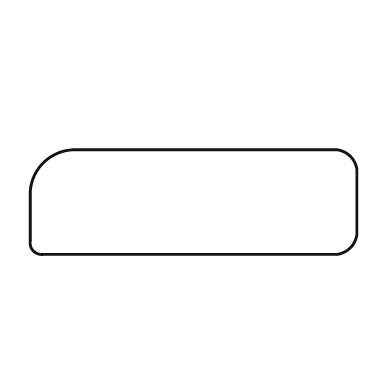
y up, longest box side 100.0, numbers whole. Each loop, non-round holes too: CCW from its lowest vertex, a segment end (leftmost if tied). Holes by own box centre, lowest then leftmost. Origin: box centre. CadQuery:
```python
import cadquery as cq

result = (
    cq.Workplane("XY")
    .moveTo(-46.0, -16.0)
    .lineTo(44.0, -16.0)
    .threePointArc((48.0, -14.0), (50.0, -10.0))
    .lineTo(50.0, 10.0)
    .threePointArc((48.0, 14.0), (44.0, 16.0))
    .lineTo(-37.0, 16.0)
    .threePointArc((-46.0, 12.0), (-50.0, 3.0))
    .lineTo(-50.0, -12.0)
    .threePointArc((-49.0, -15.0), (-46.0, -16.0))
    .close()
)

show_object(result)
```